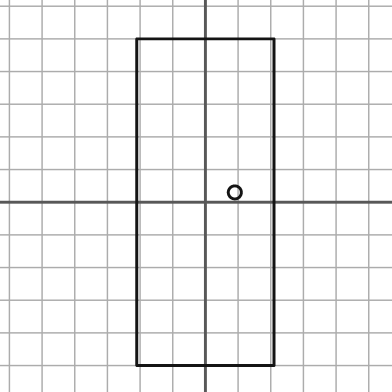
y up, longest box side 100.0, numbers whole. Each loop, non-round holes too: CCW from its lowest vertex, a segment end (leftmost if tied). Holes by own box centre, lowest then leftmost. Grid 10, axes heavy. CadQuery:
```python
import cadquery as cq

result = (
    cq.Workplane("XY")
    .moveTo(-21.0, -50.0)
    .lineTo(21.0, -50.0)
    .lineTo(21.0, 50.0)
    .lineTo(-21.0, 50.0)
    .close()
    .moveTo(9.0, 3.0)
    .circle(2.0)
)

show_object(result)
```